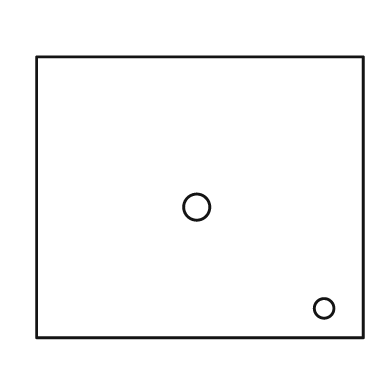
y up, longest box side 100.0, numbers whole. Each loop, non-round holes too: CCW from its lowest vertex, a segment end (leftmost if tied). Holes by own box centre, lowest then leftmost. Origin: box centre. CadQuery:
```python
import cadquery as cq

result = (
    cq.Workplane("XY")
    .moveTo(-50.0, -43.0)
    .lineTo(50.0, -43.0)
    .lineTo(50.0, 43.0)
    .lineTo(-50.0, 43.0)
    .close()
    .moveTo(38.0, -34.0)
    .circle(3.0)
    .moveTo(-1.0, -3.0)
    .circle(4.0)
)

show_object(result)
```